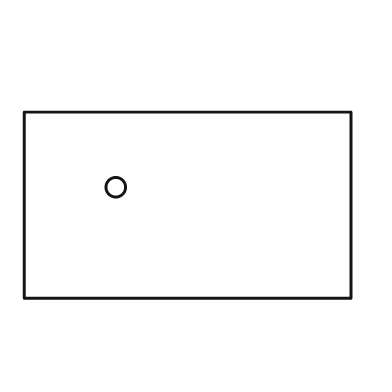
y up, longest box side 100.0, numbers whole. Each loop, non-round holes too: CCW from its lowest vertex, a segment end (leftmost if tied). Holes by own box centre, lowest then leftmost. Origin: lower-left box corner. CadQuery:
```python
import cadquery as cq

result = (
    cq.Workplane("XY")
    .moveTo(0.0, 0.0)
    .lineTo(100.0, 0.0)
    .lineTo(100.0, 57.0)
    .lineTo(0.0, 57.0)
    .close()
    .moveTo(28.0, 34.0)
    .circle(3.0)
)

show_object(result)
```